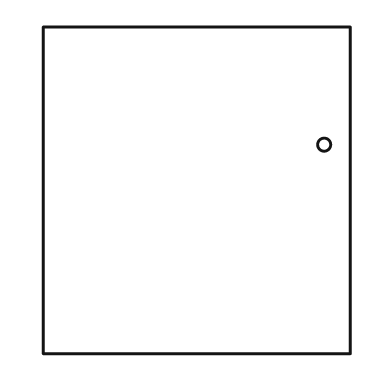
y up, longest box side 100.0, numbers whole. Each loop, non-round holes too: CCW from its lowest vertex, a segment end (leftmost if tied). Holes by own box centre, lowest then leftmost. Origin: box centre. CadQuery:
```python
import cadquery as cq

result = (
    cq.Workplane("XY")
    .moveTo(-47.0, -50.0)
    .lineTo(47.0, -50.0)
    .lineTo(47.0, 50.0)
    .lineTo(-47.0, 50.0)
    .close()
    .moveTo(39.0, 14.0)
    .circle(2.0)
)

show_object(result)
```